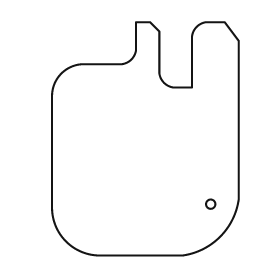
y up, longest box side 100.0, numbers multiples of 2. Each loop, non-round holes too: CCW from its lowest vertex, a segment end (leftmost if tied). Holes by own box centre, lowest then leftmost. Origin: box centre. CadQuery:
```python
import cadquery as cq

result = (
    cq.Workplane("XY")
    .moveTo(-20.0, -50.0)
    .lineTo(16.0, -50.0)
    .threePointArc((32.0, -42.0), (40.0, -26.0))
    .lineTo(40.0, 42.0)
    .lineTo(34.0, 50.0)
    .lineTo(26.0, 50.0)
    .threePointArc((22.0, 48.0), (20.0, 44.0))
    .lineTo(20.0, 22.0)
    .lineTo(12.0, 22.0)
    .threePointArc((8.0, 24.0), (6.0, 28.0))
    .lineTo(6.0, 46.0)
    .lineTo(2.0, 50.0)
    .lineTo(-4.0, 50.0)
    .lineTo(-4.0, 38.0)
    .threePointArc((-6.0, 34.0), (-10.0, 32.0))
    .lineTo(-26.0, 32.0)
    .threePointArc((-36.0, 28.0), (-40.0, 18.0))
    .lineTo(-40.0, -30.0)
    .threePointArc((-34.0, -44.0), (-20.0, -50.0))
    .close()
    .moveTo(28.0, -28.0)
    .circle(2.0)
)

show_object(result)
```